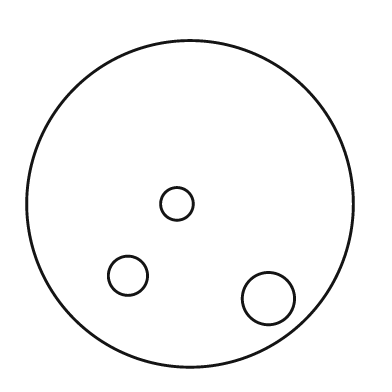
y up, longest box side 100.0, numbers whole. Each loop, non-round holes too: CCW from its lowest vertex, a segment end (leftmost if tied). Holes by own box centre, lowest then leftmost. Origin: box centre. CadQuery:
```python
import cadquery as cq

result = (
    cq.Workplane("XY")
    .moveTo(0.0, 0.0)
    .circle(50.0)
    .moveTo(24.0, -29.0)
    .circle(8.0)
    .moveTo(-19.0, -22.0)
    .circle(6.0)
    .moveTo(-4.0, 0.0)
    .circle(5.0)
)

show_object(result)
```